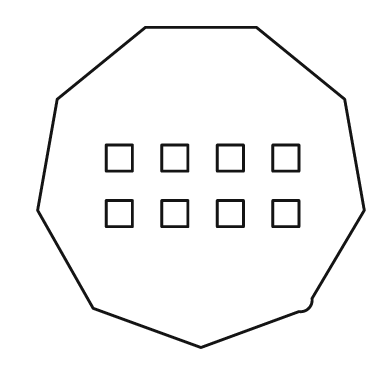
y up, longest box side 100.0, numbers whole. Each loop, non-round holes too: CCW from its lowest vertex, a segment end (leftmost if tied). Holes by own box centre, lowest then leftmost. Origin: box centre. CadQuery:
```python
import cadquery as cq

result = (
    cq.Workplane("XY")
    .moveTo(0.0, -49.0)
    .lineTo(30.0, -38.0)
    .threePointArc((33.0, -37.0), (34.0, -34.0))
    .lineTo(50.0, -7.0)
    .lineTo(44.0, 27.0)
    .lineTo(17.0, 49.0)
    .lineTo(-17.0, 49.0)
    .lineTo(-44.0, 27.0)
    .lineTo(-50.0, -7.0)
    .lineTo(-33.0, -37.0)
    .close()
    .moveTo(-29.0, -12.0)
    .lineTo(-21.0, -12.0)
    .lineTo(-21.0, -4.0)
    .lineTo(-29.0, -4.0)
    .close()
    .moveTo(-12.0, -12.0)
    .lineTo(-4.0, -12.0)
    .lineTo(-4.0, -4.0)
    .lineTo(-12.0, -4.0)
    .close()
    .moveTo(5.0, -12.0)
    .lineTo(13.0, -12.0)
    .lineTo(13.0, -4.0)
    .lineTo(5.0, -4.0)
    .close()
    .moveTo(22.0, -12.0)
    .lineTo(30.0, -12.0)
    .lineTo(30.0, -4.0)
    .lineTo(22.0, -4.0)
    .close()
    .moveTo(-29.0, 5.0)
    .lineTo(-21.0, 5.0)
    .lineTo(-21.0, 13.0)
    .lineTo(-29.0, 13.0)
    .close()
    .moveTo(-12.0, 5.0)
    .lineTo(-4.0, 5.0)
    .lineTo(-4.0, 13.0)
    .lineTo(-12.0, 13.0)
    .close()
    .moveTo(5.0, 5.0)
    .lineTo(13.0, 5.0)
    .lineTo(13.0, 13.0)
    .lineTo(5.0, 13.0)
    .close()
    .moveTo(22.0, 5.0)
    .lineTo(30.0, 5.0)
    .lineTo(30.0, 13.0)
    .lineTo(22.0, 13.0)
    .close()
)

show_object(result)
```